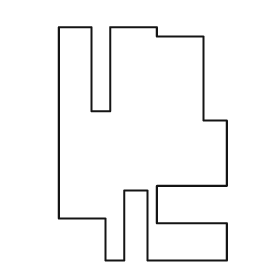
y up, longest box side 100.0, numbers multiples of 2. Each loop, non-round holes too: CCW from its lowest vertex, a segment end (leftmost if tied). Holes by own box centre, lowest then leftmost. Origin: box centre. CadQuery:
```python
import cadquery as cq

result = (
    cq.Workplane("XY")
    .moveTo(-16.0, -50.0)
    .lineTo(-8.0, -50.0)
    .lineTo(-8.0, -20.0)
    .lineTo(2.0, -20.0)
    .lineTo(2.0, -50.0)
    .lineTo(36.0, -50.0)
    .lineTo(36.0, -34.0)
    .lineTo(6.0, -34.0)
    .lineTo(6.0, -18.0)
    .lineTo(36.0, -18.0)
    .lineTo(36.0, 10.0)
    .lineTo(26.0, 10.0)
    .lineTo(26.0, 46.0)
    .lineTo(6.0, 46.0)
    .lineTo(6.0, 50.0)
    .lineTo(-14.0, 50.0)
    .lineTo(-14.0, 14.0)
    .lineTo(-22.0, 14.0)
    .lineTo(-22.0, 50.0)
    .lineTo(-36.0, 50.0)
    .lineTo(-36.0, -32.0)
    .lineTo(-16.0, -32.0)
    .close()
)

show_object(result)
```